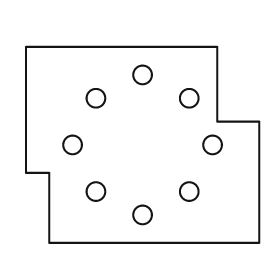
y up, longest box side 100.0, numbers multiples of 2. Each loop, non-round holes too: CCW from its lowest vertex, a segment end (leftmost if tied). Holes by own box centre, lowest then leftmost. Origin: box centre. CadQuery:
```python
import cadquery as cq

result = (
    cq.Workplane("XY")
    .moveTo(-40.0, -42.0)
    .lineTo(50.0, -42.0)
    .lineTo(50.0, 10.0)
    .lineTo(32.0, 10.0)
    .lineTo(32.0, 42.0)
    .lineTo(-50.0, 42.0)
    .lineTo(-50.0, -12.0)
    .lineTo(-40.0, -12.0)
    .close()
    .moveTo(0.0, -30.0)
    .circle(4.0)
    .moveTo(-20.0, -20.0)
    .circle(4.0)
    .moveTo(20.0, -20.0)
    .circle(4.0)
    .moveTo(-30.0, 0.0)
    .circle(4.0)
    .moveTo(30.0, 0.0)
    .circle(4.0)
    .moveTo(-20.0, 20.0)
    .circle(4.0)
    .moveTo(20.0, 20.0)
    .circle(4.0)
    .moveTo(0.0, 30.0)
    .circle(4.0)
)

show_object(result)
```